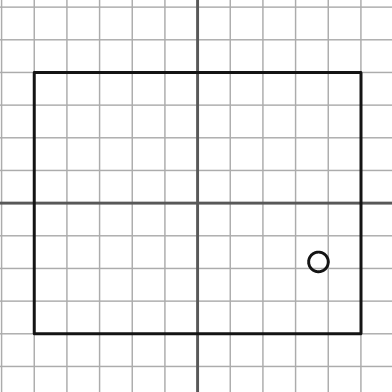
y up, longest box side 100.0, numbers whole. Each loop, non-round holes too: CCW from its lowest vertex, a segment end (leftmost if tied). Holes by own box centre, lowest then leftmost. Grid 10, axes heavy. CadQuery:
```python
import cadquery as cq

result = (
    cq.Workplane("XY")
    .moveTo(-50.0, -40.0)
    .lineTo(50.0, -40.0)
    .lineTo(50.0, 40.0)
    .lineTo(-50.0, 40.0)
    .close()
    .moveTo(37.0, -18.0)
    .circle(3.0)
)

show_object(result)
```